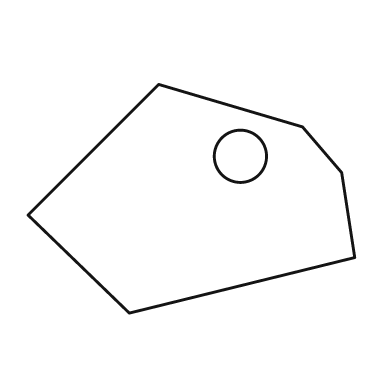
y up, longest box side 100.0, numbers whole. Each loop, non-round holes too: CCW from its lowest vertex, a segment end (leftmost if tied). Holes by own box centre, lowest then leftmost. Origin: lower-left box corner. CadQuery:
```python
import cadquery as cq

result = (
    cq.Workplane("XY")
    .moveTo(31.0, 0.0)
    .lineTo(100.0, 17.0)
    .lineTo(96.0, 43.0)
    .lineTo(84.0, 57.0)
    .lineTo(40.0, 70.0)
    .lineTo(0.0, 30.0)
    .close()
    .moveTo(65.0, 48.0)
    .circle(8.0)
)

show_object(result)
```